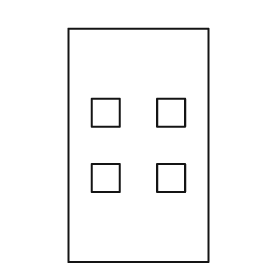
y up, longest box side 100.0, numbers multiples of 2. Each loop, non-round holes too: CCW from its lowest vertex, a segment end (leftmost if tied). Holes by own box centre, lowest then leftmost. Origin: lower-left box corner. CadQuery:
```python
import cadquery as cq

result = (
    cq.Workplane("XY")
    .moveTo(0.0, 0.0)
    .lineTo(60.0, 0.0)
    .lineTo(60.0, 100.0)
    .lineTo(0.0, 100.0)
    .close()
    .moveTo(10.0, 30.0)
    .lineTo(22.0, 30.0)
    .lineTo(22.0, 42.0)
    .lineTo(10.0, 42.0)
    .close()
    .moveTo(38.0, 30.0)
    .lineTo(50.0, 30.0)
    .lineTo(50.0, 42.0)
    .lineTo(38.0, 42.0)
    .close()
    .moveTo(10.0, 58.0)
    .lineTo(22.0, 58.0)
    .lineTo(22.0, 70.0)
    .lineTo(10.0, 70.0)
    .close()
    .moveTo(38.0, 58.0)
    .lineTo(50.0, 58.0)
    .lineTo(50.0, 70.0)
    .lineTo(38.0, 70.0)
    .close()
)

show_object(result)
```